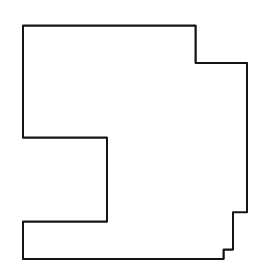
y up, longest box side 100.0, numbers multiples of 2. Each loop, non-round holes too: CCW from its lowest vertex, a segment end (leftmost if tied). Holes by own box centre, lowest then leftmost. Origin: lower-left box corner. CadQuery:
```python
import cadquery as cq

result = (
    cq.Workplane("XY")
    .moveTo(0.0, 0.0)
    .lineTo(86.0, 0.0)
    .lineTo(86.0, 4.0)
    .lineTo(90.0, 4.0)
    .lineTo(90.0, 20.0)
    .lineTo(96.0, 20.0)
    .lineTo(96.0, 84.0)
    .lineTo(74.0, 84.0)
    .lineTo(74.0, 100.0)
    .lineTo(0.0, 100.0)
    .lineTo(0.0, 52.0)
    .lineTo(36.0, 52.0)
    .lineTo(36.0, 16.0)
    .lineTo(0.0, 16.0)
    .close()
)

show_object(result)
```